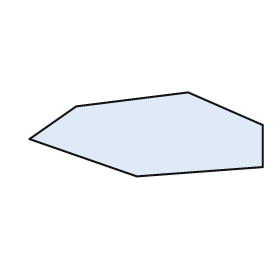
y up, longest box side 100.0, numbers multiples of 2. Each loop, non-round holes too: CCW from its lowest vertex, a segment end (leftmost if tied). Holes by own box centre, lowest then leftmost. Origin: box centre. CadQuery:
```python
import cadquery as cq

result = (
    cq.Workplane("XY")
    .moveTo(-4.0, -18.0)
    .lineTo(50.0, -14.0)
    .lineTo(50.0, 4.0)
    .lineTo(18.0, 18.0)
    .lineTo(-30.0, 12.0)
    .lineTo(-50.0, -2.0)
    .close()
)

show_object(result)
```